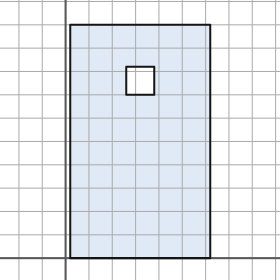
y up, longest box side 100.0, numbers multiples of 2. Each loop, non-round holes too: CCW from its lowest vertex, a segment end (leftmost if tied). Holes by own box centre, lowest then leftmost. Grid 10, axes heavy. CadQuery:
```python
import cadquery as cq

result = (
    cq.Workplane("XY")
    .moveTo(2.0, 0.0)
    .lineTo(62.0, 0.0)
    .lineTo(62.0, 100.0)
    .lineTo(2.0, 100.0)
    .close()
    .moveTo(26.0, 70.0)
    .lineTo(38.0, 70.0)
    .lineTo(38.0, 82.0)
    .lineTo(26.0, 82.0)
    .close()
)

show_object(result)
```